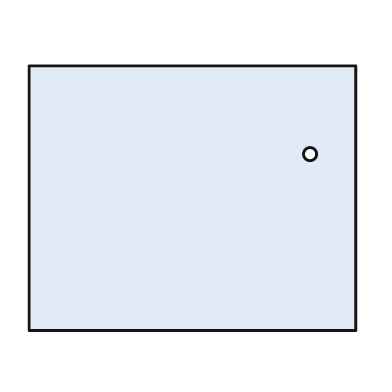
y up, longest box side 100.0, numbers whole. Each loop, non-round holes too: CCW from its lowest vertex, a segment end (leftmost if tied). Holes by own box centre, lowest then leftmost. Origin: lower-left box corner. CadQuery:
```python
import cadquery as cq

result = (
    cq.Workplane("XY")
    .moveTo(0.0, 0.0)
    .lineTo(100.0, 0.0)
    .lineTo(100.0, 81.0)
    .lineTo(0.0, 81.0)
    .close()
    .moveTo(86.0, 54.0)
    .circle(2.0)
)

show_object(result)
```